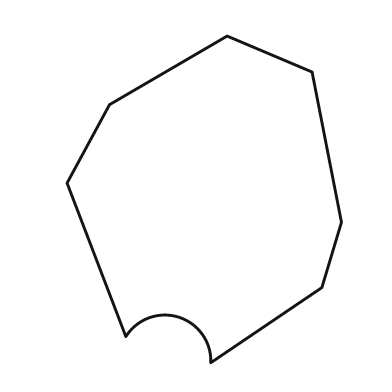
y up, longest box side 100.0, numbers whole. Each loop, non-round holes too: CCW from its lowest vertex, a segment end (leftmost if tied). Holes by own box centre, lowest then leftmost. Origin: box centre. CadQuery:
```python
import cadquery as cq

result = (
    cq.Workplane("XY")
    .moveTo(2.0, -50.0)
    .lineTo(36.0, -27.0)
    .lineTo(42.0, -7.0)
    .lineTo(33.0, 39.0)
    .lineTo(7.0, 50.0)
    .lineTo(-29.0, 29.0)
    .lineTo(-42.0, 5.0)
    .lineTo(-24.0, -42.0)
    .threePointArc((-8.0, -36.0), (2.0, -50.0))
    .close()
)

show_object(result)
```